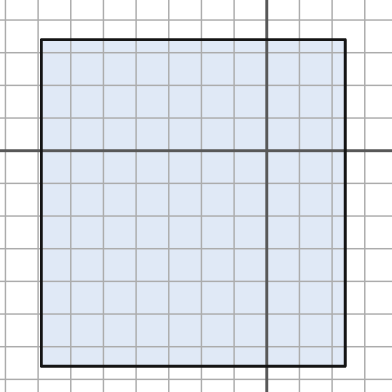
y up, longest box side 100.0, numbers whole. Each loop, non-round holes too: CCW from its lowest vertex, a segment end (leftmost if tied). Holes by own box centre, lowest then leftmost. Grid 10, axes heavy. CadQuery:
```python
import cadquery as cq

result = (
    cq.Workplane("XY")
    .moveTo(-69.0, -66.0)
    .lineTo(24.0, -66.0)
    .lineTo(24.0, 34.0)
    .lineTo(-69.0, 34.0)
    .close()
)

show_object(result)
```